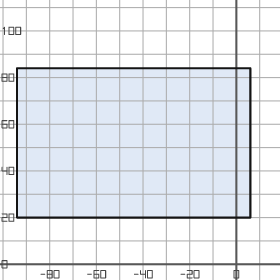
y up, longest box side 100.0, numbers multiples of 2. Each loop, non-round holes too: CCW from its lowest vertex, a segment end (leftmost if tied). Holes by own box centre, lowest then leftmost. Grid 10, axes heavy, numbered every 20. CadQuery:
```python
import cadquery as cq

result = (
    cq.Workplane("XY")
    .moveTo(-94.0, 20.0)
    .lineTo(6.0, 20.0)
    .lineTo(6.0, 84.0)
    .lineTo(-94.0, 84.0)
    .close()
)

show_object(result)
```